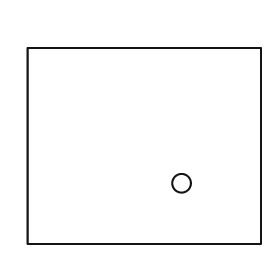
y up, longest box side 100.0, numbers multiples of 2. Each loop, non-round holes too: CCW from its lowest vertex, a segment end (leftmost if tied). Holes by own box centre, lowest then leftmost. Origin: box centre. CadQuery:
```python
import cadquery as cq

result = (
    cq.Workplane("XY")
    .moveTo(-50.0, -42.0)
    .lineTo(50.0, -42.0)
    .lineTo(50.0, 42.0)
    .lineTo(-50.0, 42.0)
    .close()
    .moveTo(16.0, -16.0)
    .circle(4.0)
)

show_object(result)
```